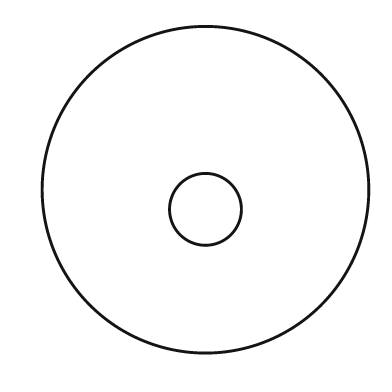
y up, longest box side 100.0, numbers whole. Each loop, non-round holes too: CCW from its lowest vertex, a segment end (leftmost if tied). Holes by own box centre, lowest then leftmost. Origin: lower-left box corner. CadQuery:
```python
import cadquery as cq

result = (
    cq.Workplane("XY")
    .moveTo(50.0, 50.0)
    .circle(50.0)
    .moveTo(50.0, 44.0)
    .circle(11.0)
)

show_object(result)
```